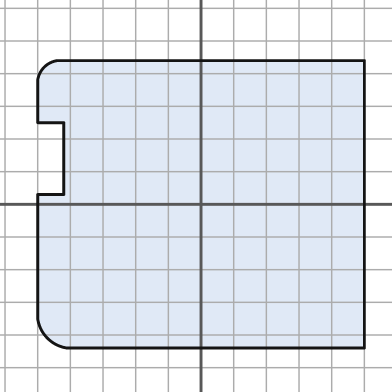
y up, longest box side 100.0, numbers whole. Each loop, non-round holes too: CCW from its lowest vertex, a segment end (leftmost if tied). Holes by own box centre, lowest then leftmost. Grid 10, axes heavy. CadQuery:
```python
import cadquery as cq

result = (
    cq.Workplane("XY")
    .moveTo(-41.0, -44.0)
    .lineTo(50.0, -44.0)
    .lineTo(50.0, 44.0)
    .lineTo(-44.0, 44.0)
    .threePointArc((-48.0, 42.0), (-50.0, 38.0))
    .lineTo(-50.0, 25.0)
    .lineTo(-42.0, 25.0)
    .lineTo(-42.0, 3.0)
    .lineTo(-50.0, 3.0)
    .lineTo(-50.0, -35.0)
    .threePointArc((-47.0, -41.0), (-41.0, -44.0))
    .close()
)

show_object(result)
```